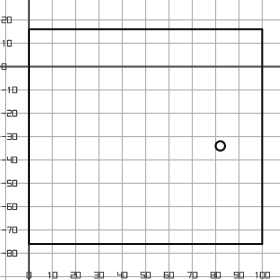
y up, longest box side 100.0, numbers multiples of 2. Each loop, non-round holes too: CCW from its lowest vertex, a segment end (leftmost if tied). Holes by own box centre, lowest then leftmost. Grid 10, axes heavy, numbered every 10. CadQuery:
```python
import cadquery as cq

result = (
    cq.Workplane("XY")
    .moveTo(0.0, -76.0)
    .lineTo(100.0, -76.0)
    .lineTo(100.0, 16.0)
    .lineTo(0.0, 16.0)
    .close()
    .moveTo(82.0, -34.0)
    .circle(2.0)
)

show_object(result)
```